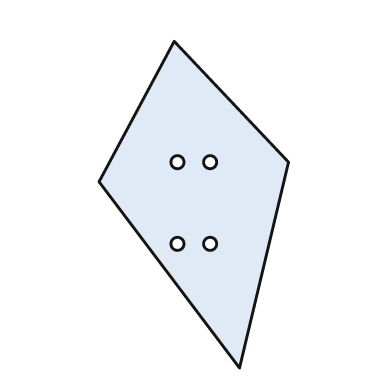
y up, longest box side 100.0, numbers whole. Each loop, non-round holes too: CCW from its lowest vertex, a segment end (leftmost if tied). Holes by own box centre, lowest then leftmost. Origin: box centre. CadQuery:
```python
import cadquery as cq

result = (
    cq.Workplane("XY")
    .moveTo(14.0, -50.0)
    .lineTo(29.0, 13.0)
    .lineTo(-6.0, 50.0)
    .lineTo(-29.0, 7.0)
    .close()
    .moveTo(-5.0, -12.0)
    .circle(2.0)
    .moveTo(5.0, -12.0)
    .circle(2.0)
    .moveTo(-5.0, 13.0)
    .circle(2.0)
    .moveTo(5.0, 13.0)
    .circle(2.0)
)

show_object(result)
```